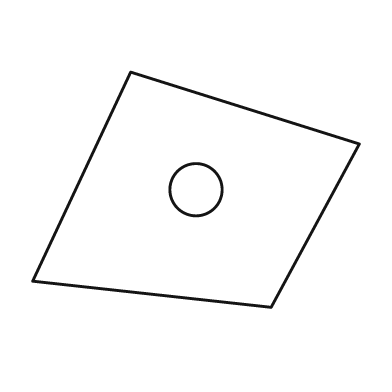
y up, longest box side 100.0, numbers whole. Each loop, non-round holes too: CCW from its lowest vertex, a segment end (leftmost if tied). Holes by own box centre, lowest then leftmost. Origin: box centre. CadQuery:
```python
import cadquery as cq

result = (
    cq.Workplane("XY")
    .moveTo(23.0, -36.0)
    .lineTo(50.0, 14.0)
    .lineTo(-20.0, 36.0)
    .lineTo(-50.0, -28.0)
    .close()
    .moveTo(0.0, 0.0)
    .circle(8.0)
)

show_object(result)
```